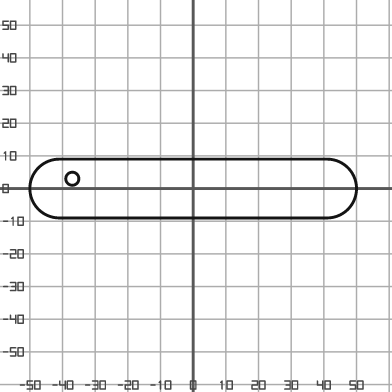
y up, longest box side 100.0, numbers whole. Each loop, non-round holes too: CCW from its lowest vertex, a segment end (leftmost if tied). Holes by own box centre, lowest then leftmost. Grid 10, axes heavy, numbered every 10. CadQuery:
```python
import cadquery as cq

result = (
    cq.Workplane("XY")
    .moveTo(-41.0, -9.0)
    .lineTo(41.0, -9.0)
    .threePointArc((50.0, 0.0), (41.0, 9.0))
    .lineTo(-41.0, 9.0)
    .threePointArc((-50.0, 0.0), (-41.0, -9.0))
    .close()
    .moveTo(-37.0, 3.0)
    .circle(2.0)
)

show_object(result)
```